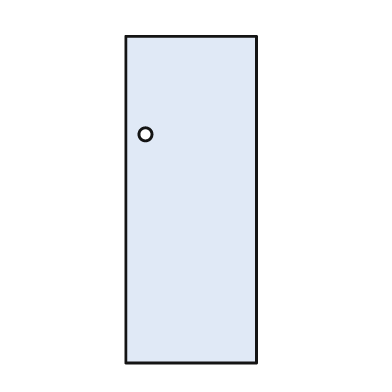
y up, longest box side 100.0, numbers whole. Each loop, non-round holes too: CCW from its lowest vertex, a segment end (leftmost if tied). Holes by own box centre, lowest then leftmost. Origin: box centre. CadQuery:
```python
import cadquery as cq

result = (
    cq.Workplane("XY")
    .moveTo(-20.0, -50.0)
    .lineTo(20.0, -50.0)
    .lineTo(20.0, 50.0)
    .lineTo(-20.0, 50.0)
    .close()
    .moveTo(-14.0, 20.0)
    .circle(2.0)
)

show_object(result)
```